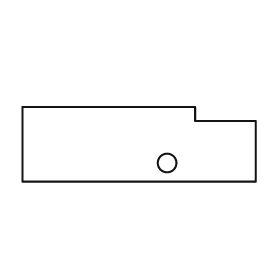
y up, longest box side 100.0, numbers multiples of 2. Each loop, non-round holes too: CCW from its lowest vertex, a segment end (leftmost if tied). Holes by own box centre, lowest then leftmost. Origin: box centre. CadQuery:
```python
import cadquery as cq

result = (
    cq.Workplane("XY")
    .moveTo(-50.0, -16.0)
    .lineTo(50.0, -16.0)
    .lineTo(50.0, 10.0)
    .lineTo(24.0, 10.0)
    .lineTo(24.0, 16.0)
    .lineTo(-50.0, 16.0)
    .close()
    .moveTo(12.0, -8.0)
    .circle(4.0)
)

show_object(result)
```